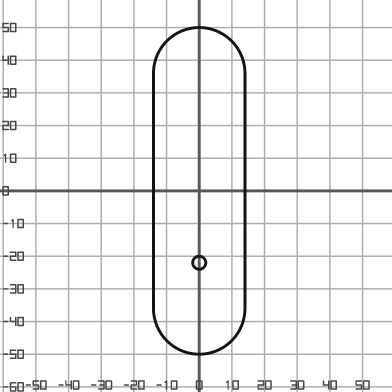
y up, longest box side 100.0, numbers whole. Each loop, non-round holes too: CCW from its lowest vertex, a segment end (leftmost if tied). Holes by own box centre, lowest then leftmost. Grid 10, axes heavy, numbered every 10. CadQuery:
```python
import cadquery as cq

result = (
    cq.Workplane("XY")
    .moveTo(-14.0, -36.0)
    .threePointArc((0.0, -50.0), (14.0, -36.0))
    .lineTo(14.0, 36.0)
    .threePointArc((0.0, 50.0), (-14.0, 36.0))
    .close()
    .moveTo(0.0, -22.0)
    .circle(2.0)
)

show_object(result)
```